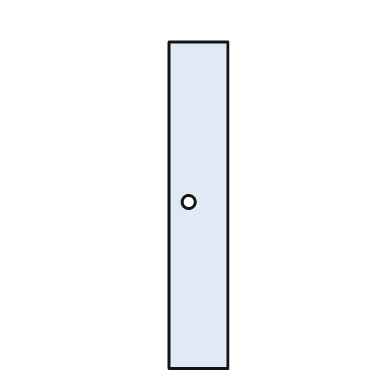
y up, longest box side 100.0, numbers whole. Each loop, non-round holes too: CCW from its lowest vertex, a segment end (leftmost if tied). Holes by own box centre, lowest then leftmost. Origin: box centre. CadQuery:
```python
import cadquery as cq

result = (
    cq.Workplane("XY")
    .moveTo(-9.0, -50.0)
    .lineTo(9.0, -50.0)
    .lineTo(9.0, 50.0)
    .lineTo(-9.0, 50.0)
    .close()
    .moveTo(-3.0, 1.0)
    .circle(2.0)
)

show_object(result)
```